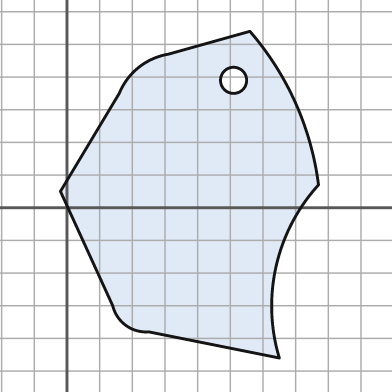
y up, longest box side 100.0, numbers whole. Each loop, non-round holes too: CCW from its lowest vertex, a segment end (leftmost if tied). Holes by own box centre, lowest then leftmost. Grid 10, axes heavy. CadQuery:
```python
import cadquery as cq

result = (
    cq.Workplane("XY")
    .moveTo(65.0, -46.0)
    .threePointArc((64.0, -18.0), (77.0, 7.0))
    .threePointArc((70.0, 32.0), (56.0, 54.0))
    .lineTo(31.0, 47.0)
    .threePointArc((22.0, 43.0), (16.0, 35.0))
    .lineTo(-2.0, 5.0)
    .lineTo(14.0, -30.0)
    .threePointArc((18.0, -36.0), (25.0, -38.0))
    .close()
    .moveTo(51.0, 39.0)
    .circle(4.0)
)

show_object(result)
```